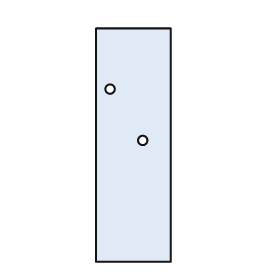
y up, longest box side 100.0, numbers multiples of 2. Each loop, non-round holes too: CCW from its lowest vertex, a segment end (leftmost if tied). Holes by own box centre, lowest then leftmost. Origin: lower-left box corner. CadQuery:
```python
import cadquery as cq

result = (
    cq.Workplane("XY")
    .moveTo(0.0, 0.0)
    .lineTo(32.0, 0.0)
    .lineTo(32.0, 100.0)
    .lineTo(0.0, 100.0)
    .close()
    .moveTo(20.0, 52.0)
    .circle(2.0)
    .moveTo(6.0, 74.0)
    .circle(2.0)
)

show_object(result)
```